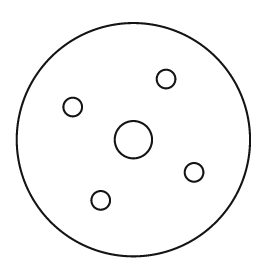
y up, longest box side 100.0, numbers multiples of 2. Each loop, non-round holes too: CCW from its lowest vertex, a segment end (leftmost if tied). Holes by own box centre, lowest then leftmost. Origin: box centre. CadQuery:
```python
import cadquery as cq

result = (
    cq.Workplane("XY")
    .moveTo(0.0, 0.0)
    .circle(50.0)
    .moveTo(-14.0, -26.0)
    .circle(4.0)
    .moveTo(26.0, -14.0)
    .circle(4.0)
    .moveTo(0.0, 0.0)
    .circle(8.0)
    .moveTo(-26.0, 14.0)
    .circle(4.0)
    .moveTo(14.0, 26.0)
    .circle(4.0)
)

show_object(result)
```